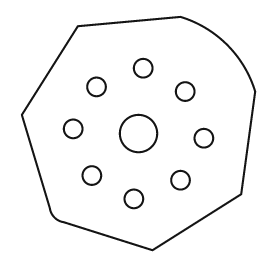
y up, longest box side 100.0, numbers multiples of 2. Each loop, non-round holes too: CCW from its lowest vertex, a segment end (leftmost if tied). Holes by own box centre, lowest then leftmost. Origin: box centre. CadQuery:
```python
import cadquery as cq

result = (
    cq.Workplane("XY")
    .moveTo(6.0, -50.0)
    .lineTo(44.0, -26.0)
    .lineTo(50.0, 18.0)
    .threePointArc((38.0, 38.0), (18.0, 50.0))
    .lineTo(-26.0, 46.0)
    .lineTo(-50.0, 8.0)
    .lineTo(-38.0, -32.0)
    .threePointArc((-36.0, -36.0), (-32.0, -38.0))
    .close()
    .moveTo(-2.0, -28.0)
    .circle(4.0)
    .moveTo(18.0, -20.0)
    .circle(4.0)
    .moveTo(-20.0, -18.0)
    .circle(4.0)
    .moveTo(28.0, -2.0)
    .circle(4.0)
    .moveTo(0.0, 0.0)
    .circle(8.0)
    .moveTo(-28.0, 2.0)
    .circle(4.0)
    .moveTo(20.0, 18.0)
    .circle(4.0)
    .moveTo(-18.0, 20.0)
    .circle(4.0)
    .moveTo(2.0, 28.0)
    .circle(4.0)
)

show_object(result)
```